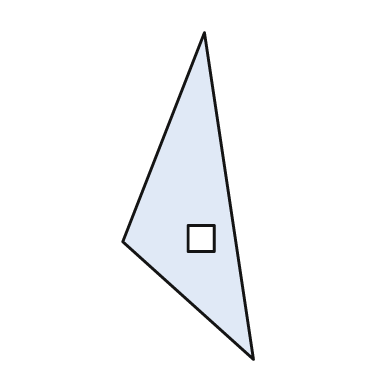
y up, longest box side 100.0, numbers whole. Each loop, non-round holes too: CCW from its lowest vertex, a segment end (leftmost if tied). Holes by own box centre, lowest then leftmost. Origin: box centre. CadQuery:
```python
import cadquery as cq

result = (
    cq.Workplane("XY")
    .moveTo(20.0, -50.0)
    .lineTo(5.0, 50.0)
    .lineTo(-20.0, -14.0)
    .close()
    .moveTo(0.0, -17.0)
    .lineTo(8.0, -17.0)
    .lineTo(8.0, -9.0)
    .lineTo(0.0, -9.0)
    .close()
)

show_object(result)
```